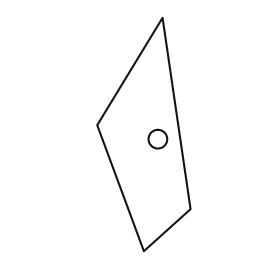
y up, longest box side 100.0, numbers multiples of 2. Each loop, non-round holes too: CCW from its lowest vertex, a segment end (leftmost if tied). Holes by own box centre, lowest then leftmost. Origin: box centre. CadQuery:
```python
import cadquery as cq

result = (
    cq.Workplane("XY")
    .moveTo(0.0, -50.0)
    .lineTo(20.0, -32.0)
    .lineTo(8.0, 50.0)
    .lineTo(-20.0, 4.0)
    .close()
    .moveTo(6.0, -2.0)
    .circle(4.0)
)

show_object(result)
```